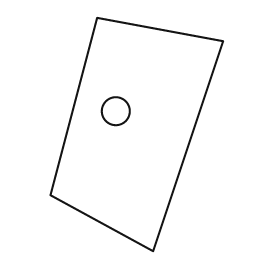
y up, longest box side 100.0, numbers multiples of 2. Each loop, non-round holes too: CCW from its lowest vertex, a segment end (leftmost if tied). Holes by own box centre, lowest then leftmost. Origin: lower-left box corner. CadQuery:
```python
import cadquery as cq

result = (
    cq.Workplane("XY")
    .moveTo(44.0, 0.0)
    .lineTo(74.0, 90.0)
    .lineTo(20.0, 100.0)
    .lineTo(0.0, 24.0)
    .close()
    .moveTo(28.0, 60.0)
    .circle(6.0)
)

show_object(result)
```